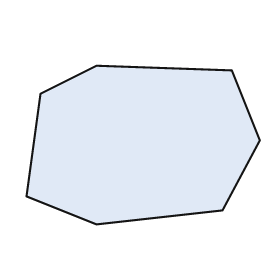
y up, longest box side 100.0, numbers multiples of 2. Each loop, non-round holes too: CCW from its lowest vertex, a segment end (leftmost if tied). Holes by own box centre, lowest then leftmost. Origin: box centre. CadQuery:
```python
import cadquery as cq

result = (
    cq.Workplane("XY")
    .moveTo(-20.0, -34.0)
    .lineTo(34.0, -28.0)
    .lineTo(50.0, 2.0)
    .lineTo(38.0, 32.0)
    .lineTo(-20.0, 34.0)
    .lineTo(-44.0, 22.0)
    .lineTo(-50.0, -22.0)
    .close()
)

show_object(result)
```